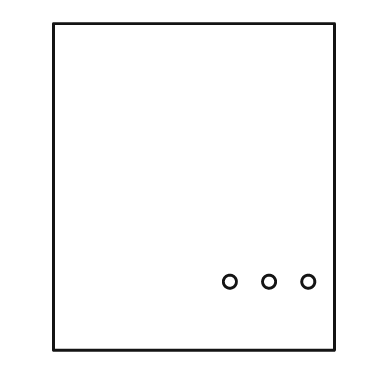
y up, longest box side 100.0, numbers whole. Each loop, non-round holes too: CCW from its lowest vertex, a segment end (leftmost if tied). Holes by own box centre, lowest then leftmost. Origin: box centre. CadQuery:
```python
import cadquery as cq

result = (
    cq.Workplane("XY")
    .moveTo(-43.0, -50.0)
    .lineTo(43.0, -50.0)
    .lineTo(43.0, 50.0)
    .lineTo(-43.0, 50.0)
    .close()
    .moveTo(11.0, -29.0)
    .circle(2.0)
    .moveTo(23.0, -29.0)
    .circle(2.0)
    .moveTo(35.0, -29.0)
    .circle(2.0)
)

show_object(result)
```